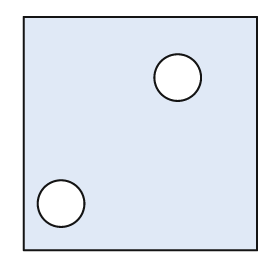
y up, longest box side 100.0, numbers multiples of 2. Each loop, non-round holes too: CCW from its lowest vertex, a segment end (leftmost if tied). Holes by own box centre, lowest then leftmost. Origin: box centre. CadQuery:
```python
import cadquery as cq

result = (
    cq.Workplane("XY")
    .moveTo(-50.0, -50.0)
    .lineTo(50.0, -50.0)
    .lineTo(50.0, 50.0)
    .lineTo(-50.0, 50.0)
    .close()
    .moveTo(-34.0, -30.0)
    .circle(10.0)
    .moveTo(16.0, 24.0)
    .circle(10.0)
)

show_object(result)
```